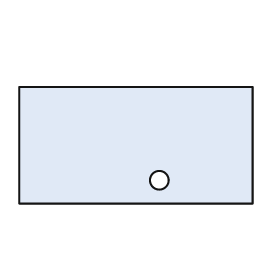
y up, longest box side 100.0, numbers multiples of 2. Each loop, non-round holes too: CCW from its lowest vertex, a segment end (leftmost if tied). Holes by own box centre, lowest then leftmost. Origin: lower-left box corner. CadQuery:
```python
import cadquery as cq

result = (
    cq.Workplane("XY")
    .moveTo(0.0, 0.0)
    .lineTo(100.0, 0.0)
    .lineTo(100.0, 50.0)
    .lineTo(0.0, 50.0)
    .close()
    .moveTo(60.0, 10.0)
    .circle(4.0)
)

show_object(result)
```